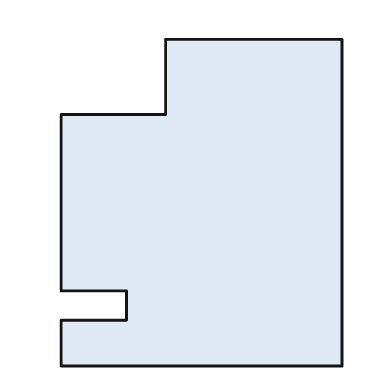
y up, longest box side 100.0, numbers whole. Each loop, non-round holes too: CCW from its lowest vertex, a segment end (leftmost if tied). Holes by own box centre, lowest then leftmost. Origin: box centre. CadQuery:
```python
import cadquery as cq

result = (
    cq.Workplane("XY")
    .moveTo(-43.0, -50.0)
    .lineTo(43.0, -50.0)
    .lineTo(43.0, 50.0)
    .lineTo(-11.0, 50.0)
    .lineTo(-11.0, 27.0)
    .lineTo(-43.0, 27.0)
    .lineTo(-43.0, -27.0)
    .lineTo(-23.0, -27.0)
    .lineTo(-23.0, -36.0)
    .lineTo(-43.0, -36.0)
    .close()
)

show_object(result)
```